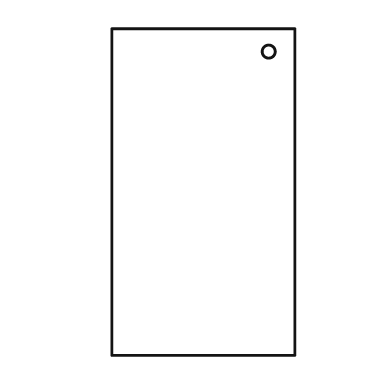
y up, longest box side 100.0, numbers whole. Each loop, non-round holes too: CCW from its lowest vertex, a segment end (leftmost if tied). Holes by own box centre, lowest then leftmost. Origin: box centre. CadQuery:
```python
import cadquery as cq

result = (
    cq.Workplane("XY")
    .moveTo(-28.0, -50.0)
    .lineTo(28.0, -50.0)
    .lineTo(28.0, 50.0)
    .lineTo(-28.0, 50.0)
    .close()
    .moveTo(20.0, 43.0)
    .circle(2.0)
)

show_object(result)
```